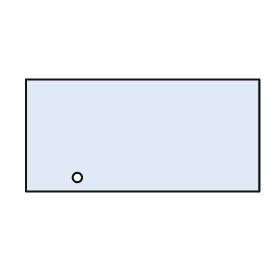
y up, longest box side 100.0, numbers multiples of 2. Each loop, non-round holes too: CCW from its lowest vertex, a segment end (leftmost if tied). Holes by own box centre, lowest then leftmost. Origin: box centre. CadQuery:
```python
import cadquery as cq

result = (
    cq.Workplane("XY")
    .moveTo(-50.0, -24.0)
    .lineTo(50.0, -24.0)
    .lineTo(50.0, 24.0)
    .lineTo(-50.0, 24.0)
    .close()
    .moveTo(-28.0, -18.0)
    .circle(2.0)
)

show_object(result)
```